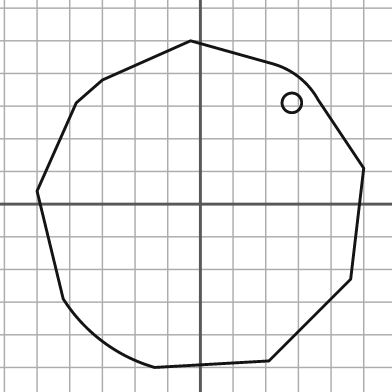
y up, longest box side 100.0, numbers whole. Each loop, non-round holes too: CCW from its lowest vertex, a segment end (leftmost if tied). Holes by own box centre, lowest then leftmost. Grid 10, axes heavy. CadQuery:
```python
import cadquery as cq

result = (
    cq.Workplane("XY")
    .moveTo(-14.0, -50.0)
    .lineTo(21.0, -48.0)
    .lineTo(46.0, -23.0)
    .lineTo(50.0, 11.0)
    .lineTo(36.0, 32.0)
    .threePointArc((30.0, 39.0), (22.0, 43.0))
    .lineTo(-3.0, 50.0)
    .lineTo(-30.0, 38.0)
    .lineTo(-38.0, 31.0)
    .lineTo(-50.0, 4.0)
    .lineTo(-42.0, -29.0)
    .threePointArc((-30.0, -42.0), (-14.0, -50.0))
    .close()
    .moveTo(28.0, 31.0)
    .circle(3.0)
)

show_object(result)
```